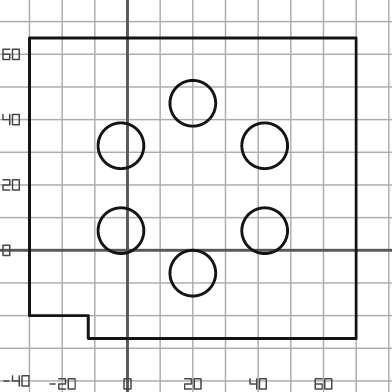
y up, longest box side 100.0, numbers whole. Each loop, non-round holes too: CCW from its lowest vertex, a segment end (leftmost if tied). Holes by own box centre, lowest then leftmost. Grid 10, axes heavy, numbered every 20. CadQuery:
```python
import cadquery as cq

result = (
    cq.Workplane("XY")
    .moveTo(-12.0, -27.0)
    .lineTo(70.0, -27.0)
    .lineTo(70.0, 65.0)
    .lineTo(-30.0, 65.0)
    .lineTo(-30.0, -20.0)
    .lineTo(-12.0, -20.0)
    .close()
    .moveTo(20.0, -7.0)
    .circle(7.0)
    .moveTo(-2.0, 6.0)
    .circle(7.0)
    .moveTo(42.0, 6.0)
    .circle(7.0)
    .moveTo(-2.0, 32.0)
    .circle(7.0)
    .moveTo(42.0, 32.0)
    .circle(7.0)
    .moveTo(20.0, 45.0)
    .circle(7.0)
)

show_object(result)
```